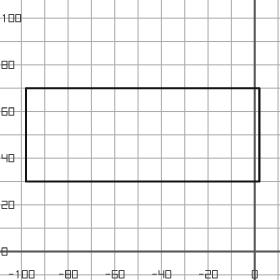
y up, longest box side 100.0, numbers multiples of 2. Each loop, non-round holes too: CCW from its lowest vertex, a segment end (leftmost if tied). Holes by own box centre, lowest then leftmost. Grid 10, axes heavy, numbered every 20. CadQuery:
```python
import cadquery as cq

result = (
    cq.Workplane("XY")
    .moveTo(-98.0, 30.0)
    .lineTo(2.0, 30.0)
    .lineTo(2.0, 70.0)
    .lineTo(-98.0, 70.0)
    .close()
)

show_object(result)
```